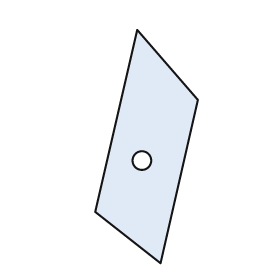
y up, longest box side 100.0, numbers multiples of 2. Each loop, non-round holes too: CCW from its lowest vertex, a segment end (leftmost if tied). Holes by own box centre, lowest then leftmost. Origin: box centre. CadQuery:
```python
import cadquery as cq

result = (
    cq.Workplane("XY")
    .moveTo(6.0, -50.0)
    .lineTo(22.0, 20.0)
    .lineTo(-4.0, 50.0)
    .lineTo(-22.0, -28.0)
    .close()
    .moveTo(-2.0, -6.0)
    .circle(4.0)
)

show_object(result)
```